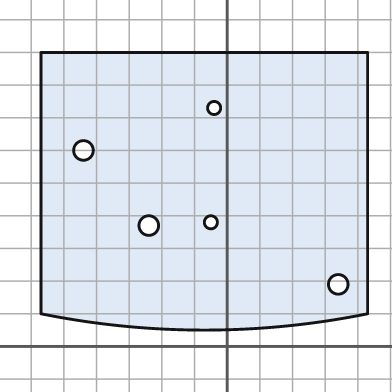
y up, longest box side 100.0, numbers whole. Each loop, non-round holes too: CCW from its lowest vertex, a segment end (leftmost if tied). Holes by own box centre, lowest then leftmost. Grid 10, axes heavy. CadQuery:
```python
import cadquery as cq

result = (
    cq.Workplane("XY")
    .moveTo(-57.0, 10.0)
    .threePointArc((-7.0, 5.0), (43.0, 10.0))
    .lineTo(43.0, 90.0)
    .lineTo(-57.0, 90.0)
    .close()
    .moveTo(34.0, 19.0)
    .circle(3.0)
    .moveTo(-24.0, 37.0)
    .circle(3.0)
    .moveTo(-5.0, 38.0)
    .circle(2.0)
    .moveTo(-44.0, 60.0)
    .circle(3.0)
    .moveTo(-4.0, 73.0)
    .circle(2.0)
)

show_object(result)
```